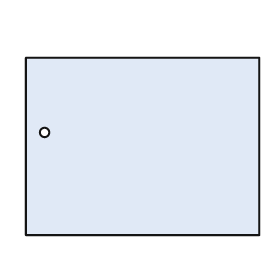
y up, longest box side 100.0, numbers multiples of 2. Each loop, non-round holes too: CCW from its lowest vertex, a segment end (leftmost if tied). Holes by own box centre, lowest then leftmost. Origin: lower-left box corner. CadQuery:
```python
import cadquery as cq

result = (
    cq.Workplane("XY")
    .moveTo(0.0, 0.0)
    .lineTo(100.0, 0.0)
    .lineTo(100.0, 76.0)
    .lineTo(0.0, 76.0)
    .close()
    .moveTo(8.0, 44.0)
    .circle(2.0)
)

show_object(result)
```